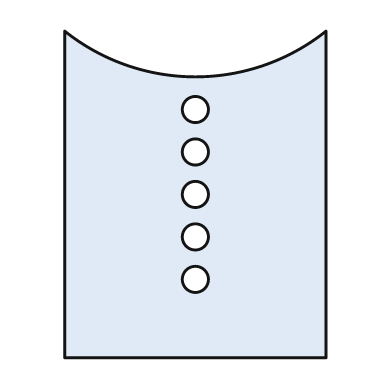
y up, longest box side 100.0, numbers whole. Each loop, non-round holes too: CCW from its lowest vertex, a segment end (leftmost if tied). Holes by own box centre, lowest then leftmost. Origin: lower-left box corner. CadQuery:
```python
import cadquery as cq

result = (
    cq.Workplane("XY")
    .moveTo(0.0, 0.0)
    .lineTo(80.0, 0.0)
    .lineTo(80.0, 100.0)
    .threePointArc((40.0, 86.0), (0.0, 100.0))
    .close()
    .moveTo(40.0, 24.0)
    .circle(4.0)
    .moveTo(40.0, 37.0)
    .circle(4.0)
    .moveTo(40.0, 50.0)
    .circle(4.0)
    .moveTo(40.0, 63.0)
    .circle(4.0)
    .moveTo(40.0, 76.0)
    .circle(4.0)
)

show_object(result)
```